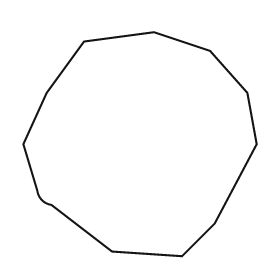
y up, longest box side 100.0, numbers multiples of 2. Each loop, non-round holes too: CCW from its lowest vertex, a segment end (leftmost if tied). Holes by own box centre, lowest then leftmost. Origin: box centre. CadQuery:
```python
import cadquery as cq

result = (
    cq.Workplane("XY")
    .moveTo(18.0, -48.0)
    .lineTo(32.0, -34.0)
    .lineTo(50.0, 0.0)
    .lineTo(46.0, 22.0)
    .lineTo(30.0, 40.0)
    .lineTo(6.0, 48.0)
    .lineTo(-24.0, 44.0)
    .lineTo(-40.0, 22.0)
    .lineTo(-50.0, 0.0)
    .lineTo(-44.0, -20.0)
    .threePointArc((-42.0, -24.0), (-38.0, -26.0))
    .lineTo(-12.0, -46.0)
    .close()
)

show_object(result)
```